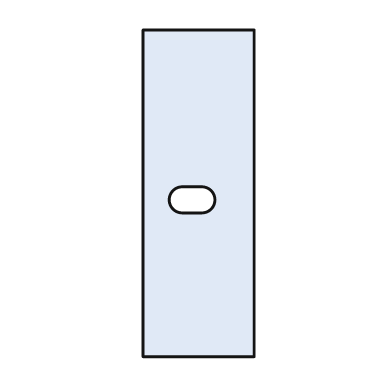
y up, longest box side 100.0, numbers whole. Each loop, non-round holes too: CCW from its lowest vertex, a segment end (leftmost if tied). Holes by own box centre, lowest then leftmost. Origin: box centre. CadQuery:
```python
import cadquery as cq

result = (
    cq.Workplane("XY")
    .moveTo(-17.0, -50.0)
    .lineTo(17.0, -50.0)
    .lineTo(17.0, 50.0)
    .lineTo(-17.0, 50.0)
    .close()
    .moveTo(-5.0, -6.0)
    .lineTo(1.0, -6.0)
    .threePointArc((5.0, -2.0), (1.0, 2.0))
    .lineTo(-5.0, 2.0)
    .threePointArc((-9.0, -2.0), (-5.0, -6.0))
    .close()
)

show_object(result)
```